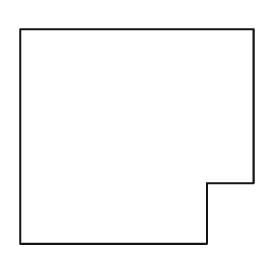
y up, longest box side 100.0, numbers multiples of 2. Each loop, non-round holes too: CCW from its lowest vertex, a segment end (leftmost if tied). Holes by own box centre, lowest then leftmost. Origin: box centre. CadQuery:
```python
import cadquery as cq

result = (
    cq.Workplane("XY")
    .moveTo(-50.0, -46.0)
    .lineTo(30.0, -46.0)
    .lineTo(30.0, -20.0)
    .lineTo(50.0, -20.0)
    .lineTo(50.0, 46.0)
    .lineTo(-50.0, 46.0)
    .close()
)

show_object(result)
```